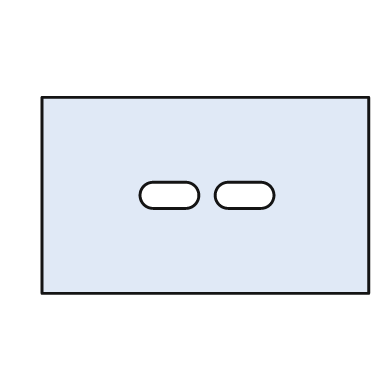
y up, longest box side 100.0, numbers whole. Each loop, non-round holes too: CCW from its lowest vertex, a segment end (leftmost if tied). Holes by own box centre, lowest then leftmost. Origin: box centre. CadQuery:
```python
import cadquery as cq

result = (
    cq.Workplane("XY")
    .moveTo(-50.0, -30.0)
    .lineTo(50.0, -30.0)
    .lineTo(50.0, 30.0)
    .lineTo(-50.0, 30.0)
    .close()
    .moveTo(-16.0, -4.0)
    .lineTo(-6.0, -4.0)
    .threePointArc((-2.0, 0.0), (-6.0, 4.0))
    .lineTo(-16.0, 4.0)
    .threePointArc((-20.0, 0.0), (-16.0, -4.0))
    .close()
    .moveTo(7.0, -4.0)
    .lineTo(17.0, -4.0)
    .threePointArc((21.0, 0.0), (17.0, 4.0))
    .lineTo(7.0, 4.0)
    .threePointArc((3.0, 0.0), (7.0, -4.0))
    .close()
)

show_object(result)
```